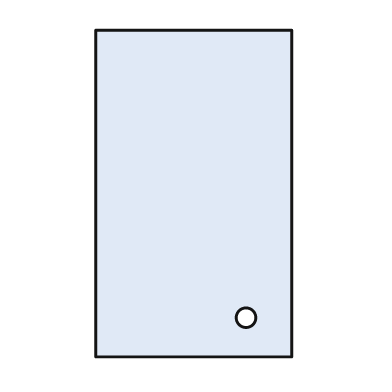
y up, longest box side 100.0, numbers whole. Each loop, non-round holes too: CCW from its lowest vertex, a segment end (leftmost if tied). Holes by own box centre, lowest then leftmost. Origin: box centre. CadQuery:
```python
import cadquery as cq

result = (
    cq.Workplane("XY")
    .moveTo(-30.0, -50.0)
    .lineTo(30.0, -50.0)
    .lineTo(30.0, 50.0)
    .lineTo(-30.0, 50.0)
    .close()
    .moveTo(16.0, -38.0)
    .circle(3.0)
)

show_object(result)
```